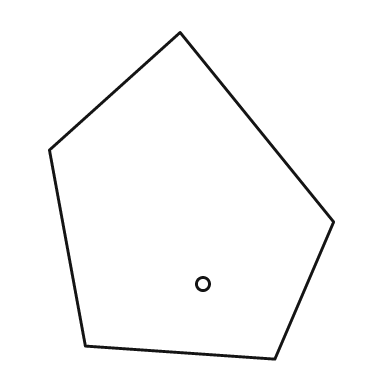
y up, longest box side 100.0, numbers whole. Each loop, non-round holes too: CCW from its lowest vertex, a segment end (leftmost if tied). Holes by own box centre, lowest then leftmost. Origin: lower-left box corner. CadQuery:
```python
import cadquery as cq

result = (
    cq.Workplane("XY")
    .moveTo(69.0, 0.0)
    .lineTo(87.0, 42.0)
    .lineTo(40.0, 100.0)
    .lineTo(0.0, 64.0)
    .lineTo(11.0, 4.0)
    .close()
    .moveTo(47.0, 23.0)
    .circle(2.0)
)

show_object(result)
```